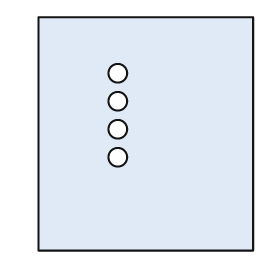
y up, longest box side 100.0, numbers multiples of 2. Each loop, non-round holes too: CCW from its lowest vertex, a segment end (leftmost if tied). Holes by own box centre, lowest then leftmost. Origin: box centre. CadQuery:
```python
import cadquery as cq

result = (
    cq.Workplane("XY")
    .moveTo(-46.0, -50.0)
    .lineTo(46.0, -50.0)
    .lineTo(46.0, 50.0)
    .lineTo(-46.0, 50.0)
    .close()
    .moveTo(-12.0, -10.0)
    .circle(4.0)
    .moveTo(-12.0, 2.0)
    .circle(4.0)
    .moveTo(-12.0, 14.0)
    .circle(4.0)
    .moveTo(-12.0, 26.0)
    .circle(4.0)
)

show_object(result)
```